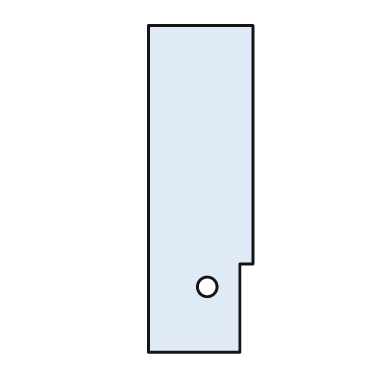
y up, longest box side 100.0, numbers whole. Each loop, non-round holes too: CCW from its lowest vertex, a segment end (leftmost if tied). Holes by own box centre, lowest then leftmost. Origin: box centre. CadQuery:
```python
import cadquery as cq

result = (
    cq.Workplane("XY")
    .moveTo(-16.0, -50.0)
    .lineTo(12.0, -50.0)
    .lineTo(12.0, -23.0)
    .lineTo(16.0, -23.0)
    .lineTo(16.0, 50.0)
    .lineTo(-16.0, 50.0)
    .close()
    .moveTo(2.0, -30.0)
    .circle(3.0)
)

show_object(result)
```